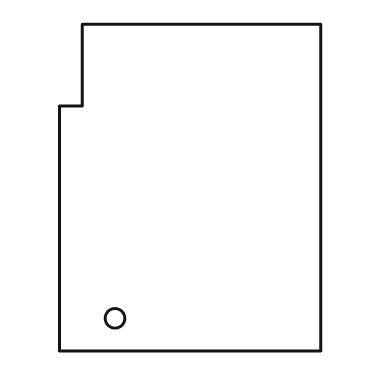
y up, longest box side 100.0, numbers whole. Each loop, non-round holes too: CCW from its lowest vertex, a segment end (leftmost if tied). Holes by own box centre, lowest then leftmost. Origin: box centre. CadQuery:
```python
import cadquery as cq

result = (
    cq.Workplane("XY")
    .moveTo(-40.0, -50.0)
    .lineTo(40.0, -50.0)
    .lineTo(40.0, 50.0)
    .lineTo(-33.0, 50.0)
    .lineTo(-33.0, 25.0)
    .lineTo(-40.0, 25.0)
    .close()
    .moveTo(-23.0, -40.0)
    .circle(3.0)
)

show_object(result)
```